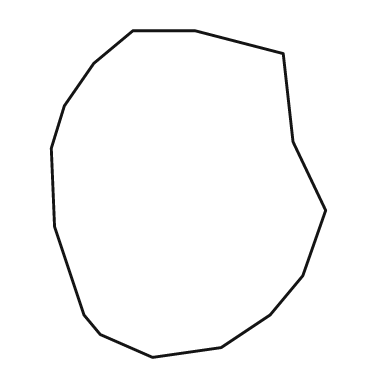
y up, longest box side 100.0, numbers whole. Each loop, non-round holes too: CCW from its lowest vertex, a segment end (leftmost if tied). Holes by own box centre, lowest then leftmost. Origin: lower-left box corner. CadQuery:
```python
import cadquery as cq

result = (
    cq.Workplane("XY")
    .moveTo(31.0, 0.0)
    .lineTo(52.0, 3.0)
    .lineTo(67.0, 13.0)
    .lineTo(77.0, 25.0)
    .lineTo(84.0, 45.0)
    .lineTo(74.0, 66.0)
    .lineTo(71.0, 93.0)
    .lineTo(44.0, 100.0)
    .lineTo(25.0, 100.0)
    .lineTo(13.0, 90.0)
    .lineTo(4.0, 77.0)
    .lineTo(0.0, 64.0)
    .lineTo(1.0, 40.0)
    .lineTo(10.0, 13.0)
    .lineTo(15.0, 7.0)
    .close()
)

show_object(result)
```